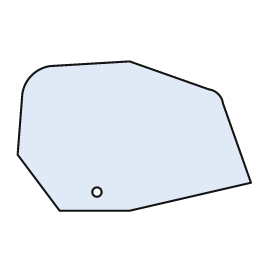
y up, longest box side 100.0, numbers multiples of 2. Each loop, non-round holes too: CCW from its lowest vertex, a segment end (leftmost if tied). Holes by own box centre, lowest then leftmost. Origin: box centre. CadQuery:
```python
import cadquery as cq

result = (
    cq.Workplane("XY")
    .moveTo(-32.0, -32.0)
    .lineTo(-2.0, -32.0)
    .lineTo(50.0, -20.0)
    .lineTo(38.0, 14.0)
    .threePointArc((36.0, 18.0), (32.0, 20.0))
    .lineTo(-2.0, 32.0)
    .lineTo(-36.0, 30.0)
    .threePointArc((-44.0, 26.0), (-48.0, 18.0))
    .lineTo(-50.0, -8.0)
    .close()
    .moveTo(-16.0, -24.0)
    .circle(2.0)
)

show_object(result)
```